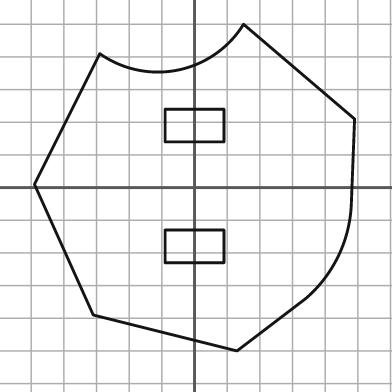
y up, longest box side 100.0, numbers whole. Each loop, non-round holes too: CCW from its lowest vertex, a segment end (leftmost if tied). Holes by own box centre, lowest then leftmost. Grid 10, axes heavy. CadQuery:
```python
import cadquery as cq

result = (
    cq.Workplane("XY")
    .moveTo(13.0, -50.0)
    .lineTo(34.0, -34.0)
    .threePointArc((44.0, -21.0), (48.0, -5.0))
    .lineTo(49.0, 21.0)
    .lineTo(15.0, 50.0)
    .threePointArc((-5.0, 36.0), (-29.0, 41.0))
    .lineTo(-49.0, 1.0)
    .lineTo(-31.0, -39.0)
    .close()
    .moveTo(-9.0, -23.0)
    .lineTo(9.0, -23.0)
    .lineTo(9.0, -13.0)
    .lineTo(-9.0, -13.0)
    .close()
    .moveTo(-9.0, 14.0)
    .lineTo(9.0, 14.0)
    .lineTo(9.0, 24.0)
    .lineTo(-9.0, 24.0)
    .close()
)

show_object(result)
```